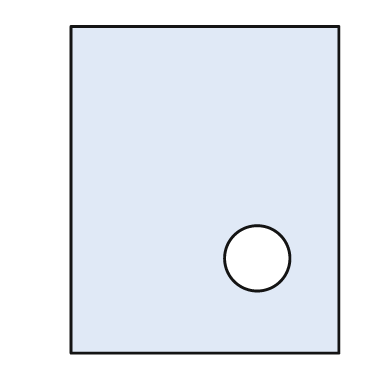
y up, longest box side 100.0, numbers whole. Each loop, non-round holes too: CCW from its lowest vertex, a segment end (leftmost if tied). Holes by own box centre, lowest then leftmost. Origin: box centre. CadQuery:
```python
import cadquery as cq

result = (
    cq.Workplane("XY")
    .moveTo(-41.0, -50.0)
    .lineTo(41.0, -50.0)
    .lineTo(41.0, 50.0)
    .lineTo(-41.0, 50.0)
    .close()
    .moveTo(16.0, -21.0)
    .circle(10.0)
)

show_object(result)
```